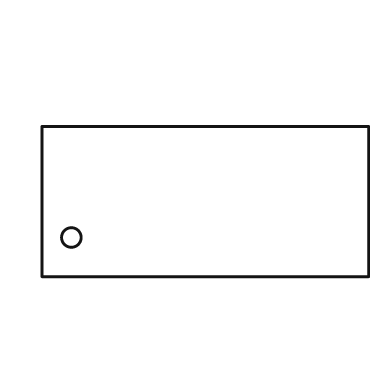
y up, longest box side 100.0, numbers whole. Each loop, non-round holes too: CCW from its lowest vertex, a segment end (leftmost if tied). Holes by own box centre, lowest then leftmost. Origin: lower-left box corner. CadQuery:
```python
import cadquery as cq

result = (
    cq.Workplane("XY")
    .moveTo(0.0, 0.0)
    .lineTo(100.0, 0.0)
    .lineTo(100.0, 46.0)
    .lineTo(0.0, 46.0)
    .close()
    .moveTo(9.0, 12.0)
    .circle(3.0)
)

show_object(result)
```